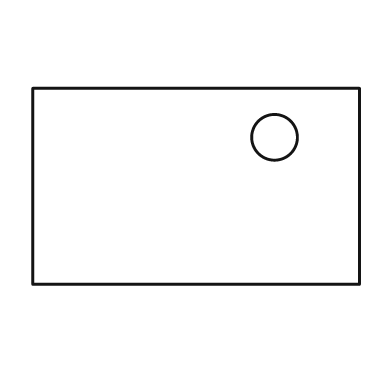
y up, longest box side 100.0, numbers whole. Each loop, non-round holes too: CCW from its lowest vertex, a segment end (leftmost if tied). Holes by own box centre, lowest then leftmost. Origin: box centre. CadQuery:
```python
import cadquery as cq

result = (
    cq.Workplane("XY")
    .moveTo(-50.0, -30.0)
    .lineTo(50.0, -30.0)
    .lineTo(50.0, 30.0)
    .lineTo(-50.0, 30.0)
    .close()
    .moveTo(24.0, 15.0)
    .circle(7.0)
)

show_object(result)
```